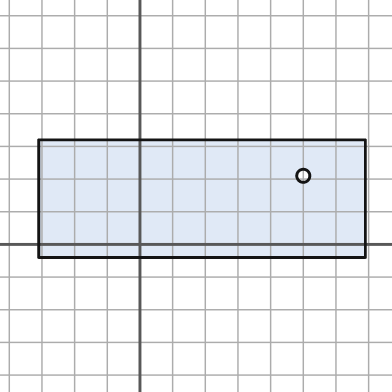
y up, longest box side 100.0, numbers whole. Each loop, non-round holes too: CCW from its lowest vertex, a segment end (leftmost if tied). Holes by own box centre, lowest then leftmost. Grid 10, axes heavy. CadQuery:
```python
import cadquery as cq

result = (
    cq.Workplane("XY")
    .moveTo(-31.0, -4.0)
    .lineTo(69.0, -4.0)
    .lineTo(69.0, 32.0)
    .lineTo(-31.0, 32.0)
    .close()
    .moveTo(50.0, 21.0)
    .circle(2.0)
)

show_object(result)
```